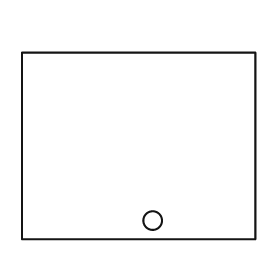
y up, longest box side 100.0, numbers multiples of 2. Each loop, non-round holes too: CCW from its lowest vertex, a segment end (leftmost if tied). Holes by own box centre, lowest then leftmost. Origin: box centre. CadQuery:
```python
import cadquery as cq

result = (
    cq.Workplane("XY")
    .moveTo(-50.0, -40.0)
    .lineTo(50.0, -40.0)
    .lineTo(50.0, 40.0)
    .lineTo(-50.0, 40.0)
    .close()
    .moveTo(6.0, -32.0)
    .circle(4.0)
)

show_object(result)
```